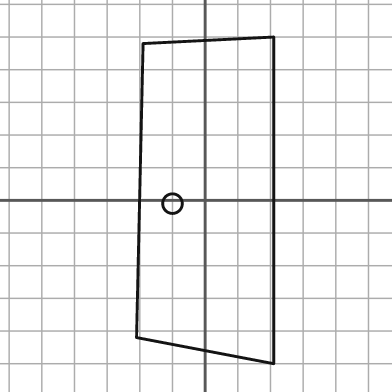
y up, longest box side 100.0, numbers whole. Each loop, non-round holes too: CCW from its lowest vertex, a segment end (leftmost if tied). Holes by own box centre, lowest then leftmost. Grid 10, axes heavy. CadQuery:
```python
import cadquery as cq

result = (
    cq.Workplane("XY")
    .moveTo(21.0, -50.0)
    .lineTo(21.0, 50.0)
    .lineTo(-19.0, 48.0)
    .lineTo(-21.0, -42.0)
    .close()
    .moveTo(-10.0, -1.0)
    .circle(3.0)
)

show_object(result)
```